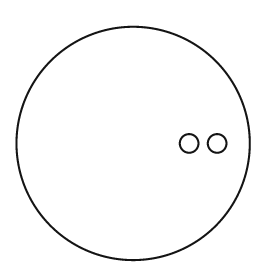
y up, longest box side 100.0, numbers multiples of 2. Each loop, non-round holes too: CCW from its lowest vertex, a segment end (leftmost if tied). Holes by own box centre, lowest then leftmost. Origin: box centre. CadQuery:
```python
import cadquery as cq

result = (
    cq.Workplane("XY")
    .moveTo(0.0, 0.0)
    .circle(50.0)
    .moveTo(24.0, 0.0)
    .circle(4.0)
    .moveTo(36.0, 0.0)
    .circle(4.0)
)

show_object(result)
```